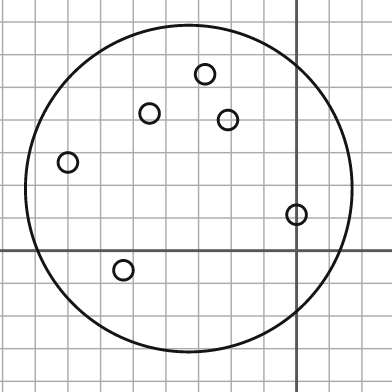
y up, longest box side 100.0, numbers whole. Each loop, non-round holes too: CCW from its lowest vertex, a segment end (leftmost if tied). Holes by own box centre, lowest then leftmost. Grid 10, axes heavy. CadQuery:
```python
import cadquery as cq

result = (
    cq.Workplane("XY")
    .moveTo(-33.0, 19.0)
    .circle(50.0)
    .moveTo(-53.0, -6.0)
    .circle(3.0)
    .moveTo(0.0, 11.0)
    .circle(3.0)
    .moveTo(-70.0, 27.0)
    .circle(3.0)
    .moveTo(-21.0, 40.0)
    .circle(3.0)
    .moveTo(-45.0, 42.0)
    .circle(3.0)
    .moveTo(-28.0, 54.0)
    .circle(3.0)
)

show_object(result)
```